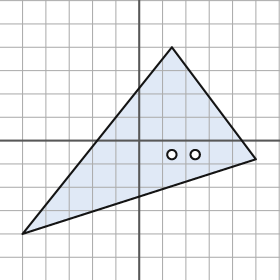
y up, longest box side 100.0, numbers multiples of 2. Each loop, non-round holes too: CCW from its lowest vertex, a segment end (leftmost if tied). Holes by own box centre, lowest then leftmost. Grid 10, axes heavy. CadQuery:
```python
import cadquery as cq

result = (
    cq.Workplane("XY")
    .moveTo(-50.0, -40.0)
    .lineTo(50.0, -8.0)
    .lineTo(14.0, 40.0)
    .close()
    .moveTo(14.0, -6.0)
    .circle(2.0)
    .moveTo(24.0, -6.0)
    .circle(2.0)
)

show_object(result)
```